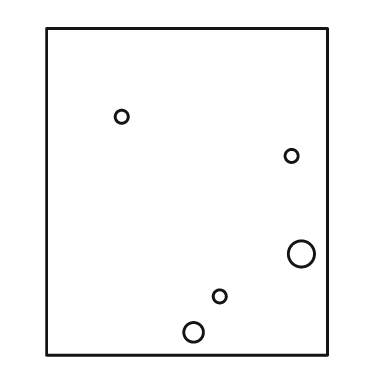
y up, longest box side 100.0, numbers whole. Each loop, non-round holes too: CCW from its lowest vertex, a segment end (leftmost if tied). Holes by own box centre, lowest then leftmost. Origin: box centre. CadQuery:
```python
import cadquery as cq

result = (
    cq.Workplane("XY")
    .moveTo(-43.0, -50.0)
    .lineTo(43.0, -50.0)
    .lineTo(43.0, 50.0)
    .lineTo(-43.0, 50.0)
    .close()
    .moveTo(2.0, -43.0)
    .circle(3.0)
    .moveTo(10.0, -32.0)
    .circle(2.0)
    .moveTo(35.0, -19.0)
    .circle(4.0)
    .moveTo(32.0, 11.0)
    .circle(2.0)
    .moveTo(-20.0, 23.0)
    .circle(2.0)
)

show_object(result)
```